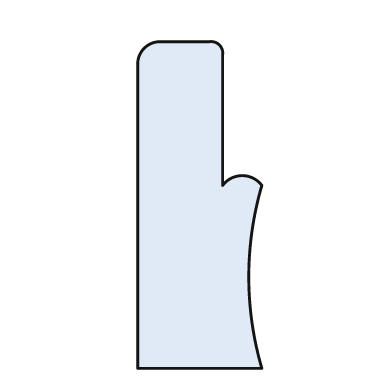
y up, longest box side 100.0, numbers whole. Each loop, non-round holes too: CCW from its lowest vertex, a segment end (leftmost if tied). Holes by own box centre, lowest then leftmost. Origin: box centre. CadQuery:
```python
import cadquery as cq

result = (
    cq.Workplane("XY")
    .moveTo(-19.0, -50.0)
    .lineTo(19.0, -50.0)
    .threePointArc((15.0, -22.0), (19.0, 6.0))
    .threePointArc((13.0, 9.0), (7.0, 6.0))
    .lineTo(7.0, 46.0)
    .threePointArc((6.0, 49.0), (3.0, 50.0))
    .lineTo(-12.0, 50.0)
    .threePointArc((-17.0, 48.0), (-19.0, 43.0))
    .close()
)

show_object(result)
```